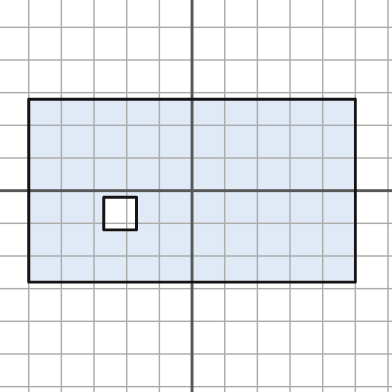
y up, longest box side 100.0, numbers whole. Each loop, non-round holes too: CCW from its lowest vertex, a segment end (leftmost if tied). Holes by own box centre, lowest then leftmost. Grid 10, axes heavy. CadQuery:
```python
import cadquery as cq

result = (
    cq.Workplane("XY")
    .moveTo(-50.0, -28.0)
    .lineTo(50.0, -28.0)
    .lineTo(50.0, 28.0)
    .lineTo(-50.0, 28.0)
    .close()
    .moveTo(-27.0, -12.0)
    .lineTo(-17.0, -12.0)
    .lineTo(-17.0, -2.0)
    .lineTo(-27.0, -2.0)
    .close()
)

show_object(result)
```